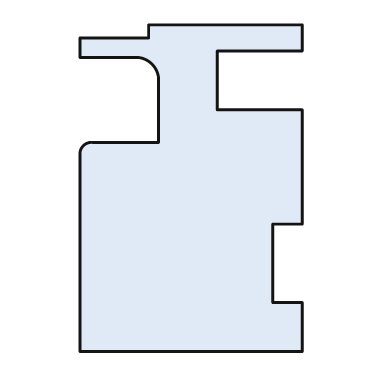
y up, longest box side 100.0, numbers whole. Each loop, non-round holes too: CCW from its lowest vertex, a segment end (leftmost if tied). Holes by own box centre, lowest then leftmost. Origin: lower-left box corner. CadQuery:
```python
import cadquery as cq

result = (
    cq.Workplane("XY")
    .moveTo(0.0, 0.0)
    .lineTo(68.0, 0.0)
    .lineTo(68.0, 15.0)
    .lineTo(59.0, 15.0)
    .lineTo(59.0, 39.0)
    .lineTo(68.0, 39.0)
    .lineTo(68.0, 74.0)
    .lineTo(42.0, 74.0)
    .lineTo(42.0, 92.0)
    .lineTo(68.0, 92.0)
    .lineTo(68.0, 100.0)
    .lineTo(21.0, 100.0)
    .lineTo(21.0, 96.0)
    .lineTo(0.0, 96.0)
    .lineTo(0.0, 90.0)
    .lineTo(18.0, 90.0)
    .threePointArc((22.0, 88.0), (24.0, 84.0))
    .lineTo(24.0, 64.0)
    .lineTo(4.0, 64.0)
    .threePointArc((1.0, 63.0), (0.0, 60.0))
    .close()
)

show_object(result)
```